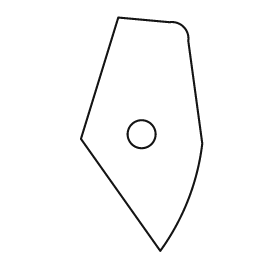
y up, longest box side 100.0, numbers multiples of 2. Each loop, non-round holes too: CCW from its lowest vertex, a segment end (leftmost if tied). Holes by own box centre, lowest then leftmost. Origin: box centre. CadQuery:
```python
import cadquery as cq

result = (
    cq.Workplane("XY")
    .moveTo(8.0, -50.0)
    .threePointArc((20.0, -28.0), (26.0, -4.0))
    .lineTo(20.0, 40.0)
    .threePointArc((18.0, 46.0), (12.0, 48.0))
    .lineTo(-10.0, 50.0)
    .lineTo(-26.0, -2.0)
    .close()
    .moveTo(0.0, 0.0)
    .circle(6.0)
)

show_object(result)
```